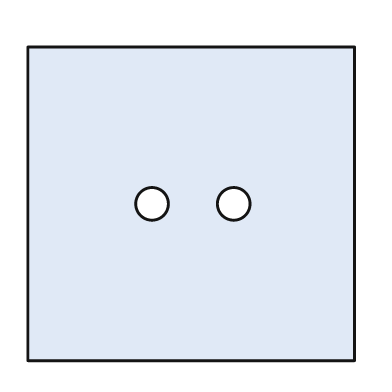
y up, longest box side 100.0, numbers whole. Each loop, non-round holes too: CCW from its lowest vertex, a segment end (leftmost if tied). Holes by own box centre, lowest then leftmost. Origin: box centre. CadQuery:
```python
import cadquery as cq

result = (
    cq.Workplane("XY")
    .moveTo(-50.0, -48.0)
    .lineTo(50.0, -48.0)
    .lineTo(50.0, 48.0)
    .lineTo(-50.0, 48.0)
    .close()
    .moveTo(-12.0, 0.0)
    .circle(5.0)
    .moveTo(13.0, 0.0)
    .circle(5.0)
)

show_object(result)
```